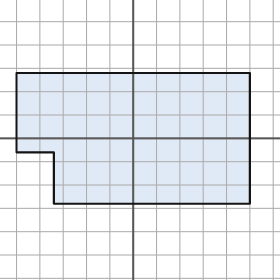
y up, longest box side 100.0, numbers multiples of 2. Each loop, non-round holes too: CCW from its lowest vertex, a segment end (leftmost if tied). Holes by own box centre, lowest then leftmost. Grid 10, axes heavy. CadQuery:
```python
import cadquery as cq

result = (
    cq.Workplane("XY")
    .moveTo(-34.0, -28.0)
    .lineTo(50.0, -28.0)
    .lineTo(50.0, 28.0)
    .lineTo(-50.0, 28.0)
    .lineTo(-50.0, -6.0)
    .lineTo(-34.0, -6.0)
    .close()
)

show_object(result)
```